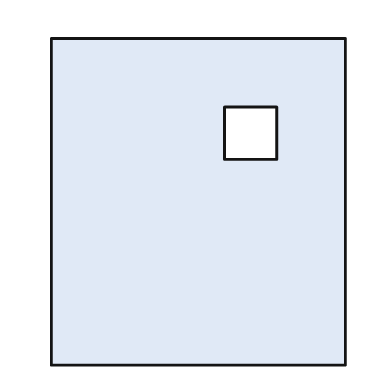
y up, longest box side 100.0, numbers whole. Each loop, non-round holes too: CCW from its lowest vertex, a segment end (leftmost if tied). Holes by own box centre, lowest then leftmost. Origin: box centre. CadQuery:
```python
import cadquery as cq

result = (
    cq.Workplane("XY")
    .moveTo(-45.0, -50.0)
    .lineTo(45.0, -50.0)
    .lineTo(45.0, 50.0)
    .lineTo(-45.0, 50.0)
    .close()
    .moveTo(8.0, 13.0)
    .lineTo(24.0, 13.0)
    .lineTo(24.0, 29.0)
    .lineTo(8.0, 29.0)
    .close()
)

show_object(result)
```